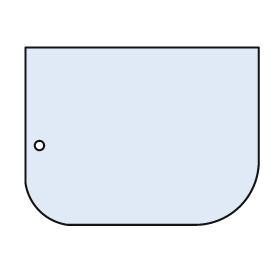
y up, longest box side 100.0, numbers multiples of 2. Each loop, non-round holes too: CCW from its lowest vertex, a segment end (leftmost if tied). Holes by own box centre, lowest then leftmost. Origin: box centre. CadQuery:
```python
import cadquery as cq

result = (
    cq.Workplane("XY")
    .moveTo(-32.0, -38.0)
    .lineTo(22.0, -38.0)
    .threePointArc((42.0, -30.0), (50.0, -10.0))
    .lineTo(50.0, 38.0)
    .lineTo(-50.0, 38.0)
    .lineTo(-50.0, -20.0)
    .threePointArc((-44.0, -32.0), (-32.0, -38.0))
    .close()
    .moveTo(-44.0, -4.0)
    .circle(2.0)
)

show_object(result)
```